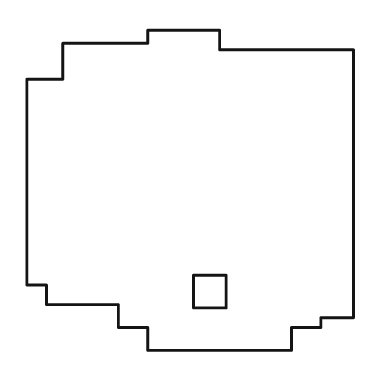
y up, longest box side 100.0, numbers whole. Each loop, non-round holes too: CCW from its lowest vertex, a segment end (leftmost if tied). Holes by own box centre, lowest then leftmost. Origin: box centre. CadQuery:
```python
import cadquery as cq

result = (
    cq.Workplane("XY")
    .moveTo(-13.0, -49.0)
    .lineTo(31.0, -49.0)
    .lineTo(31.0, -42.0)
    .lineTo(40.0, -42.0)
    .lineTo(40.0, -39.0)
    .lineTo(50.0, -39.0)
    .lineTo(50.0, 43.0)
    .lineTo(9.0, 43.0)
    .lineTo(9.0, 49.0)
    .lineTo(-13.0, 49.0)
    .lineTo(-13.0, 45.0)
    .lineTo(-39.0, 45.0)
    .lineTo(-39.0, 34.0)
    .lineTo(-50.0, 34.0)
    .lineTo(-50.0, -29.0)
    .lineTo(-44.0, -29.0)
    .lineTo(-44.0, -35.0)
    .lineTo(-22.0, -35.0)
    .lineTo(-22.0, -42.0)
    .lineTo(-13.0, -42.0)
    .close()
    .moveTo(1.0, -36.0)
    .lineTo(11.0, -36.0)
    .lineTo(11.0, -26.0)
    .lineTo(1.0, -26.0)
    .close()
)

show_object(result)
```